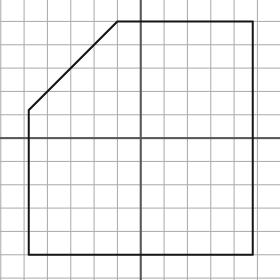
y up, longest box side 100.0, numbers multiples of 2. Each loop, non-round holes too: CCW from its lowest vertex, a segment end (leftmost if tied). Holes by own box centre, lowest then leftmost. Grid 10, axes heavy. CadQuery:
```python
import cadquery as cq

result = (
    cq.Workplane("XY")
    .moveTo(-48.0, -50.0)
    .lineTo(48.0, -50.0)
    .lineTo(48.0, 50.0)
    .lineTo(-10.0, 50.0)
    .lineTo(-48.0, 12.0)
    .close()
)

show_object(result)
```